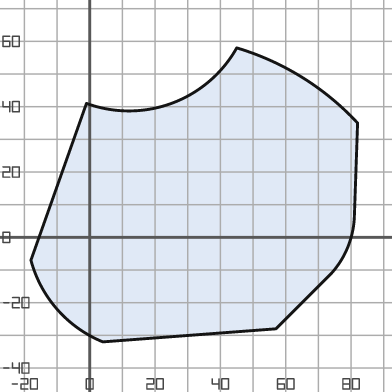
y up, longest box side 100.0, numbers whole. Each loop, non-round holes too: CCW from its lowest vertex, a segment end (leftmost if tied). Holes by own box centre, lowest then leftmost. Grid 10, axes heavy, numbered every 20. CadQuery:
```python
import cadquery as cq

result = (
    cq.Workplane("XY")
    .moveTo(4.0, -32.0)
    .lineTo(57.0, -28.0)
    .lineTo(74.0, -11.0)
    .threePointArc((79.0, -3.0), (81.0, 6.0))
    .lineTo(82.0, 35.0)
    .threePointArc((65.0, 49.0), (45.0, 58.0))
    .threePointArc((25.0, 41.0), (-1.0, 41.0))
    .lineTo(-18.0, -7.0)
    .threePointArc((-10.0, -22.0), (4.0, -32.0))
    .close()
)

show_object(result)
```